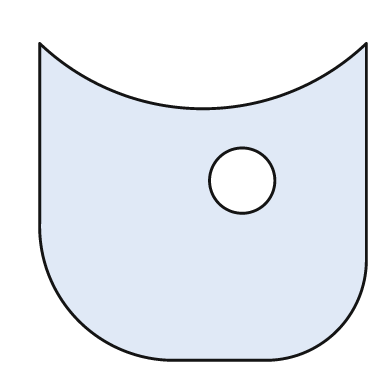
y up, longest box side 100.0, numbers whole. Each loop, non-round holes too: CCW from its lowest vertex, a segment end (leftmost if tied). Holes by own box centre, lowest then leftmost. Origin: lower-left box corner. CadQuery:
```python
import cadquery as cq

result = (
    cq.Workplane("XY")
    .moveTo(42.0, 0.0)
    .lineTo(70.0, 0.0)
    .threePointArc((91.0, 9.0), (100.0, 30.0))
    .lineTo(100.0, 97.0)
    .threePointArc((50.0, 77.0), (0.0, 97.0))
    .lineTo(0.0, 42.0)
    .threePointArc((12.0, 12.0), (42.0, 0.0))
    .close()
    .moveTo(62.0, 55.0)
    .circle(10.0)
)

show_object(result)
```